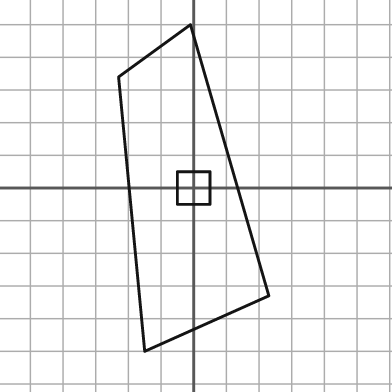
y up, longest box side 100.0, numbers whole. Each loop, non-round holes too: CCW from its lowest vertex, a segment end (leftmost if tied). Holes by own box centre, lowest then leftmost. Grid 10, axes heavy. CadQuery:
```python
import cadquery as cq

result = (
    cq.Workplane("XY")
    .moveTo(-15.0, -50.0)
    .lineTo(23.0, -33.0)
    .lineTo(-1.0, 50.0)
    .lineTo(-23.0, 34.0)
    .close()
    .moveTo(-5.0, -5.0)
    .lineTo(5.0, -5.0)
    .lineTo(5.0, 5.0)
    .lineTo(-5.0, 5.0)
    .close()
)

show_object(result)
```